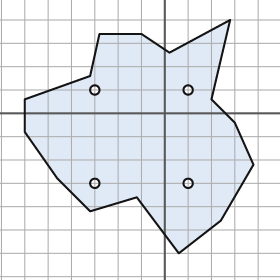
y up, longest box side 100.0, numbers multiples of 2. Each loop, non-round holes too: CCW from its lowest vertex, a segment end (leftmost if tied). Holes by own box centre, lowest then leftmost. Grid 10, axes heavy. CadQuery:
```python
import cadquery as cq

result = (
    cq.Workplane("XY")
    .moveTo(6.0, -60.0)
    .lineTo(24.0, -46.0)
    .lineTo(38.0, -22.0)
    .lineTo(30.0, -4.0)
    .lineTo(20.0, 6.0)
    .lineTo(28.0, 40.0)
    .lineTo(2.0, 26.0)
    .lineTo(-10.0, 34.0)
    .lineTo(-28.0, 34.0)
    .lineTo(-32.0, 16.0)
    .lineTo(-60.0, 6.0)
    .lineTo(-60.0, -8.0)
    .lineTo(-46.0, -28.0)
    .lineTo(-32.0, -42.0)
    .lineTo(-12.0, -36.0)
    .close()
    .moveTo(-30.0, -30.0)
    .circle(2.0)
    .moveTo(10.0, -30.0)
    .circle(2.0)
    .moveTo(-30.0, 10.0)
    .circle(2.0)
    .moveTo(10.0, 10.0)
    .circle(2.0)
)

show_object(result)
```